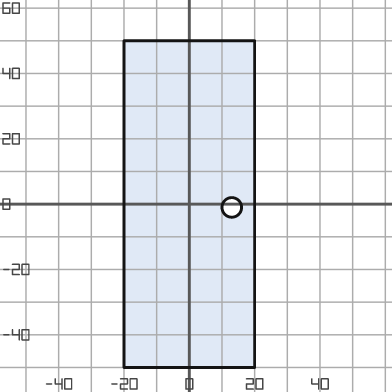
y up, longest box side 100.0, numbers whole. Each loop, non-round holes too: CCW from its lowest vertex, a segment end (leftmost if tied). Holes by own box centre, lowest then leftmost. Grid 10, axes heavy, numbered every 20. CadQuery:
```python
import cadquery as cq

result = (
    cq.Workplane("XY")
    .moveTo(-20.0, -50.0)
    .lineTo(20.0, -50.0)
    .lineTo(20.0, 50.0)
    .lineTo(-20.0, 50.0)
    .close()
    .moveTo(13.0, -1.0)
    .circle(3.0)
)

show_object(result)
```